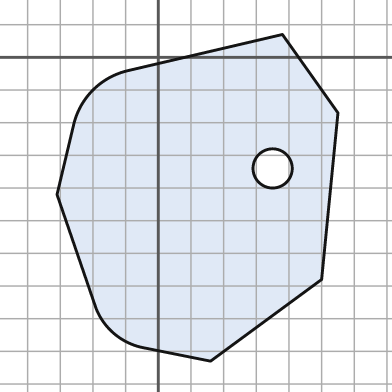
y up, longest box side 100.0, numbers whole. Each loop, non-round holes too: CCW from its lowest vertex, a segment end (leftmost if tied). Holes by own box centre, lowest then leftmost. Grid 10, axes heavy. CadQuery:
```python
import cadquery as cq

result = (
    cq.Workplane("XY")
    .moveTo(16.0, -93.0)
    .lineTo(50.0, -68.0)
    .lineTo(55.0, -17.0)
    .lineTo(38.0, 7.0)
    .lineTo(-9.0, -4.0)
    .threePointArc((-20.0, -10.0), (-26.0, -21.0))
    .lineTo(-31.0, -42.0)
    .lineTo(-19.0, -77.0)
    .threePointArc((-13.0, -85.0), (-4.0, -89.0))
    .close()
    .moveTo(35.0, -34.0)
    .circle(6.0)
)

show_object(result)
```